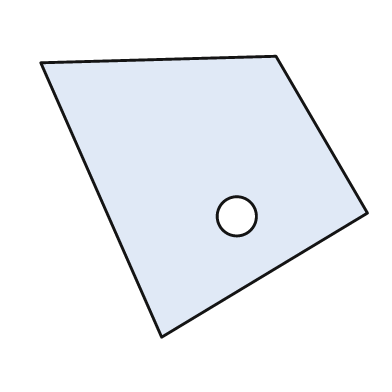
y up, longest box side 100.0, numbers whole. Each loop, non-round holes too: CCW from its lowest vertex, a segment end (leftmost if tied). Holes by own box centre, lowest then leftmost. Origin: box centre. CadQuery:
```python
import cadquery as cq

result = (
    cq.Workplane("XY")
    .moveTo(-13.0, -43.0)
    .lineTo(50.0, -5.0)
    .lineTo(22.0, 43.0)
    .lineTo(-50.0, 41.0)
    .close()
    .moveTo(10.0, -6.0)
    .circle(6.0)
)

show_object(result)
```